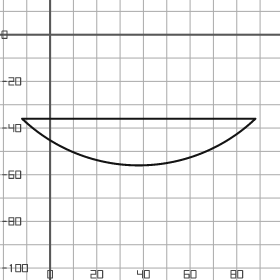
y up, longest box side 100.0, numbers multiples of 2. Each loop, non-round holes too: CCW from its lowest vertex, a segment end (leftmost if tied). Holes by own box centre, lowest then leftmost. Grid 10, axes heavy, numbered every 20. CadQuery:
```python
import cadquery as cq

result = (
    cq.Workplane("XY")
    .moveTo(-12.0, -36.0)
    .threePointArc((38.0, -56.0), (88.0, -36.0))
    .close()
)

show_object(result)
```